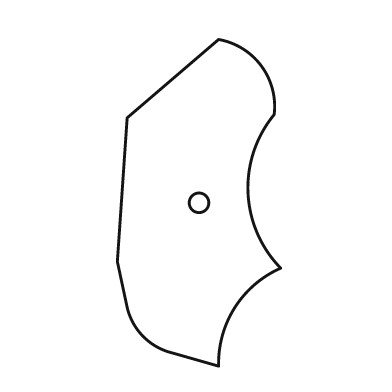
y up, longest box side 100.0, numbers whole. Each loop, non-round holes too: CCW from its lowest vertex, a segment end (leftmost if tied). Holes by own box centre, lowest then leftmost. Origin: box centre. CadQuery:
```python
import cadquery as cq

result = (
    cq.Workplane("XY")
    .moveTo(6.0, -50.0)
    .threePointArc((11.0, -32.0), (25.0, -20.0))
    .threePointArc((15.0, 3.0), (23.0, 27.0))
    .threePointArc((19.0, 42.0), (6.0, 50.0))
    .lineTo(-22.0, 26.0)
    .lineTo(-25.0, -18.0)
    .lineTo(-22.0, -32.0)
    .threePointArc((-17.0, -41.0), (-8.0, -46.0))
    .close()
    .moveTo(0.0, 0.0)
    .circle(3.0)
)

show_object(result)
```